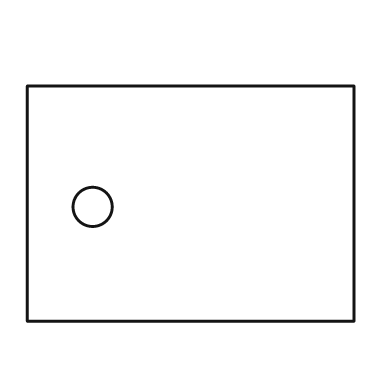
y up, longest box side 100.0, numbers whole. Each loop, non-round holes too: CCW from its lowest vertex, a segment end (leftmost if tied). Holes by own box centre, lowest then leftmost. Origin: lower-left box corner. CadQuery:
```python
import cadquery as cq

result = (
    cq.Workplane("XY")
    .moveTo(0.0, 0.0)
    .lineTo(100.0, 0.0)
    .lineTo(100.0, 72.0)
    .lineTo(0.0, 72.0)
    .close()
    .moveTo(20.0, 35.0)
    .circle(6.0)
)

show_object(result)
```